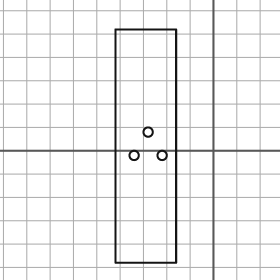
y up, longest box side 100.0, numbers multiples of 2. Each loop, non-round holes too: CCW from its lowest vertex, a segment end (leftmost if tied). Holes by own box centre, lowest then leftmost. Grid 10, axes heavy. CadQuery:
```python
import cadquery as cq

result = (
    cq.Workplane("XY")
    .moveTo(-42.0, -48.0)
    .lineTo(-16.0, -48.0)
    .lineTo(-16.0, 52.0)
    .lineTo(-42.0, 52.0)
    .close()
    .moveTo(-34.0, -2.0)
    .circle(2.0)
    .moveTo(-22.0, -2.0)
    .circle(2.0)
    .moveTo(-28.0, 8.0)
    .circle(2.0)
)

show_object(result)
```